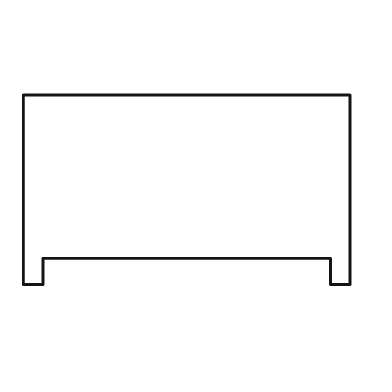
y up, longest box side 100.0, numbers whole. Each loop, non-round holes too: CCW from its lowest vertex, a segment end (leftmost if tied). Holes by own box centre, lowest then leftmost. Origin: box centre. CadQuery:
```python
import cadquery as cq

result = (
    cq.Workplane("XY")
    .moveTo(-50.0, -29.0)
    .lineTo(-44.0, -29.0)
    .lineTo(-44.0, -21.0)
    .lineTo(44.0, -21.0)
    .lineTo(44.0, -29.0)
    .lineTo(50.0, -29.0)
    .lineTo(50.0, 29.0)
    .lineTo(-50.0, 29.0)
    .close()
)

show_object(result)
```